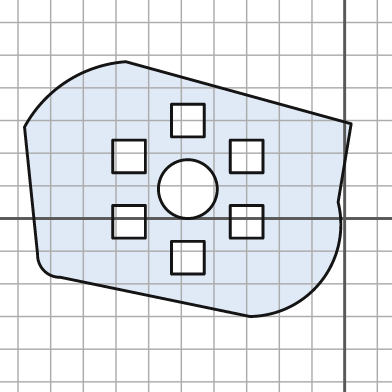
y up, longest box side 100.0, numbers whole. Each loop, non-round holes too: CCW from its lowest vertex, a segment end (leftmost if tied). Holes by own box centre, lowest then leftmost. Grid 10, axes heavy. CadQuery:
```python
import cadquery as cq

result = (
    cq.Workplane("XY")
    .moveTo(-29.0, -30.0)
    .threePointArc((-7.0, -19.0), (-2.0, 5.0))
    .lineTo(2.0, 29.0)
    .lineTo(-67.0, 48.0)
    .threePointArc((-85.0, 42.0), (-98.0, 28.0))
    .lineTo(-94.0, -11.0)
    .threePointArc((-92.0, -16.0), (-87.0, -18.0))
    .close()
    .moveTo(-53.0, -17.0)
    .lineTo(-43.0, -17.0)
    .lineTo(-43.0, -7.0)
    .lineTo(-53.0, -7.0)
    .close()
    .moveTo(-71.0, -6.0)
    .lineTo(-61.0, -6.0)
    .lineTo(-61.0, 4.0)
    .lineTo(-71.0, 4.0)
    .close()
    .moveTo(-35.0, -6.0)
    .lineTo(-25.0, -6.0)
    .lineTo(-25.0, 4.0)
    .lineTo(-35.0, 4.0)
    .close()
    .moveTo(-48.0, 9.0)
    .circle(9.0)
    .moveTo(-71.0, 14.0)
    .lineTo(-61.0, 14.0)
    .lineTo(-61.0, 24.0)
    .lineTo(-71.0, 24.0)
    .close()
    .moveTo(-35.0, 14.0)
    .lineTo(-25.0, 14.0)
    .lineTo(-25.0, 24.0)
    .lineTo(-35.0, 24.0)
    .close()
    .moveTo(-53.0, 25.0)
    .lineTo(-43.0, 25.0)
    .lineTo(-43.0, 35.0)
    .lineTo(-53.0, 35.0)
    .close()
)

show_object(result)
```